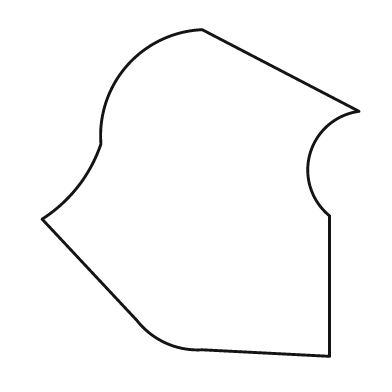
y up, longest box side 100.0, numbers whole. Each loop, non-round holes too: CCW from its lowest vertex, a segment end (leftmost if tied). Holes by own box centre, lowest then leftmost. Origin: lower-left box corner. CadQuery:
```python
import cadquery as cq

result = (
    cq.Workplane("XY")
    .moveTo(88.0, 0.0)
    .lineTo(88.0, 43.0)
    .threePointArc((82.0, 62.0), (97.0, 75.0))
    .lineTo(49.0, 100.0)
    .threePointArc((26.0, 89.0), (18.0, 65.0))
    .threePointArc((11.0, 52.0), (0.0, 42.0))
    .lineTo(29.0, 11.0)
    .threePointArc((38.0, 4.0), (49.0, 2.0))
    .close()
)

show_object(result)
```